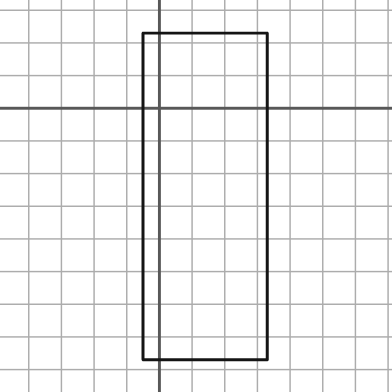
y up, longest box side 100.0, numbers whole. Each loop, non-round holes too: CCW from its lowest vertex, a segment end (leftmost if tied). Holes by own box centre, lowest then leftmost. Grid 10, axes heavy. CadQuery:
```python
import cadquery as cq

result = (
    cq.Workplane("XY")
    .moveTo(-5.0, -77.0)
    .lineTo(33.0, -77.0)
    .lineTo(33.0, 23.0)
    .lineTo(-5.0, 23.0)
    .close()
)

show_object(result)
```